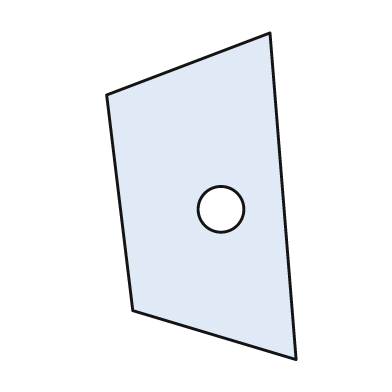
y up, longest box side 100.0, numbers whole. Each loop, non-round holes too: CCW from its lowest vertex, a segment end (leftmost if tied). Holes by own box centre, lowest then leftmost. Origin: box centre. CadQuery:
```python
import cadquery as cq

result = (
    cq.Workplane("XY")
    .moveTo(29.0, -50.0)
    .lineTo(21.0, 50.0)
    .lineTo(-29.0, 31.0)
    .lineTo(-21.0, -35.0)
    .close()
    .moveTo(6.0, -4.0)
    .circle(7.0)
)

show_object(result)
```